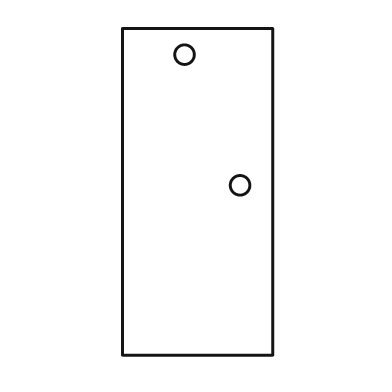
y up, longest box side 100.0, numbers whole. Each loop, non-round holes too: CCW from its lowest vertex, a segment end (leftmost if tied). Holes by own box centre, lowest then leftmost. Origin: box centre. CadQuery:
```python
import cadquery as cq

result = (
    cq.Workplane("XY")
    .moveTo(-23.0, -50.0)
    .lineTo(23.0, -50.0)
    .lineTo(23.0, 50.0)
    .lineTo(-23.0, 50.0)
    .close()
    .moveTo(13.0, 2.0)
    .circle(3.0)
    .moveTo(-4.0, 42.0)
    .circle(3.0)
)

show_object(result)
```